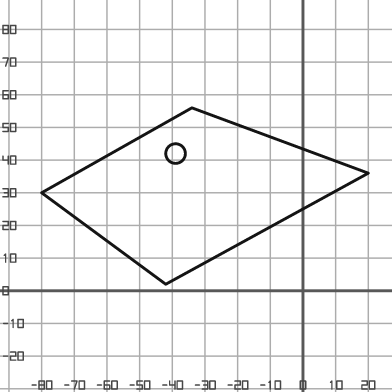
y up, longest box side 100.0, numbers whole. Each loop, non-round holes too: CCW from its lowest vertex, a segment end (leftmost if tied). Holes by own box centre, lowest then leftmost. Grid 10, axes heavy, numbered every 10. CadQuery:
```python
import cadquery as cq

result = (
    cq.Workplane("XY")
    .moveTo(-42.0, 2.0)
    .lineTo(20.0, 36.0)
    .lineTo(-34.0, 56.0)
    .lineTo(-80.0, 30.0)
    .close()
    .moveTo(-39.0, 42.0)
    .circle(3.0)
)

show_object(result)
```